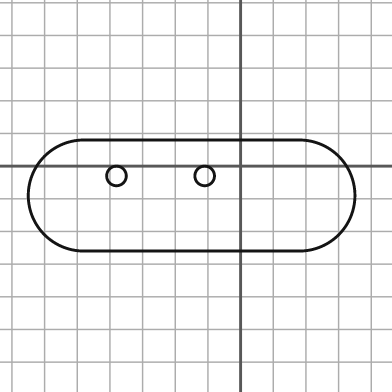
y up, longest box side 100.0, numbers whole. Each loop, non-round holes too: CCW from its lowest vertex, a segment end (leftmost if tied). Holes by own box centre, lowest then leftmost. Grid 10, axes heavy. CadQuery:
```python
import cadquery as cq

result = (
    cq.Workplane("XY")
    .moveTo(-48.0, -26.0)
    .lineTo(18.0, -26.0)
    .threePointArc((35.0, -9.0), (18.0, 8.0))
    .lineTo(-48.0, 8.0)
    .threePointArc((-65.0, -9.0), (-48.0, -26.0))
    .close()
    .moveTo(-38.0, -3.0)
    .circle(3.0)
    .moveTo(-11.0, -3.0)
    .circle(3.0)
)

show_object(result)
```